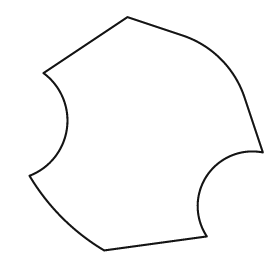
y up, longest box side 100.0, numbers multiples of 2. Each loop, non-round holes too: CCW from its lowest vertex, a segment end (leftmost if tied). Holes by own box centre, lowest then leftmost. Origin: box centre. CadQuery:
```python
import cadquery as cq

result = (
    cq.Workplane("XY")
    .moveTo(-18.0, -50.0)
    .lineTo(26.0, -44.0)
    .threePointArc((26.0, -18.0), (50.0, -8.0))
    .lineTo(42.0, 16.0)
    .threePointArc((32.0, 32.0), (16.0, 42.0))
    .lineTo(-8.0, 50.0)
    .lineTo(-44.0, 26.0)
    .threePointArc((-34.0, 2.0), (-50.0, -18.0))
    .threePointArc((-36.0, -36.0), (-18.0, -50.0))
    .close()
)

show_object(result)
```